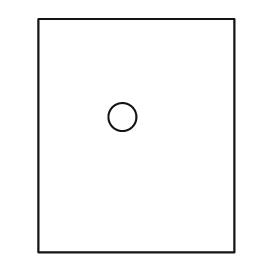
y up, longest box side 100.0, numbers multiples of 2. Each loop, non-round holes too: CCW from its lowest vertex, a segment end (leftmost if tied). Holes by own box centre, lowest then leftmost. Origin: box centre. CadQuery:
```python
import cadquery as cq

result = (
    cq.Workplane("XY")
    .moveTo(-42.0, -50.0)
    .lineTo(42.0, -50.0)
    .lineTo(42.0, 50.0)
    .lineTo(-42.0, 50.0)
    .close()
    .moveTo(-6.0, 8.0)
    .circle(6.0)
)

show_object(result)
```